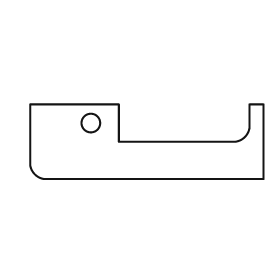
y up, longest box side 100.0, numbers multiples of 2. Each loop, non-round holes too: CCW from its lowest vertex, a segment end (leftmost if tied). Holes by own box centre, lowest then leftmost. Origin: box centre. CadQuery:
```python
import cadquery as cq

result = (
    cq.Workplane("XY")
    .moveTo(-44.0, -16.0)
    .lineTo(50.0, -16.0)
    .lineTo(50.0, 16.0)
    .lineTo(44.0, 16.0)
    .lineTo(44.0, 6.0)
    .threePointArc((42.0, 2.0), (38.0, 0.0))
    .lineTo(-12.0, 0.0)
    .lineTo(-12.0, 16.0)
    .lineTo(-50.0, 16.0)
    .lineTo(-50.0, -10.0)
    .threePointArc((-48.0, -14.0), (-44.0, -16.0))
    .close()
    .moveTo(-24.0, 8.0)
    .circle(4.0)
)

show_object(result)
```